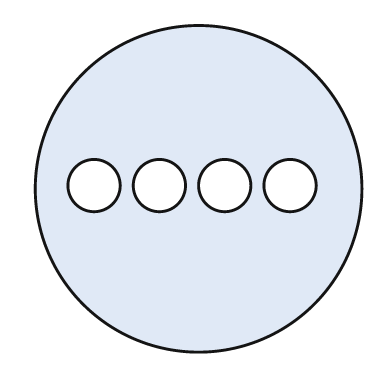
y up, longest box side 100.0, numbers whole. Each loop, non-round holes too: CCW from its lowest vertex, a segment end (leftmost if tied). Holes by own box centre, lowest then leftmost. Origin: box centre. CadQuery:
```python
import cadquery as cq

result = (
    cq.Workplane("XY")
    .moveTo(0.0, 0.0)
    .circle(50.0)
    .moveTo(-32.0, 1.0)
    .circle(8.0)
    .moveTo(-12.0, 1.0)
    .circle(8.0)
    .moveTo(8.0, 1.0)
    .circle(8.0)
    .moveTo(28.0, 1.0)
    .circle(8.0)
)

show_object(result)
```